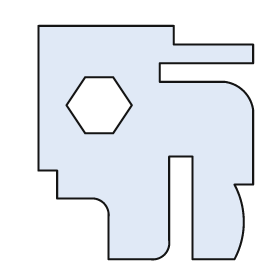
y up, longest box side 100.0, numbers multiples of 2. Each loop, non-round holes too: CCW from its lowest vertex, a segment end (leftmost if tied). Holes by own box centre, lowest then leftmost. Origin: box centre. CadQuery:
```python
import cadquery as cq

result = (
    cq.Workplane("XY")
    .moveTo(-16.0, -50.0)
    .lineTo(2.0, -50.0)
    .threePointArc((8.0, -48.0), (10.0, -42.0))
    .lineTo(10.0, -6.0)
    .lineTo(20.0, -6.0)
    .lineTo(20.0, -50.0)
    .lineTo(38.0, -50.0)
    .threePointArc((42.0, -34.0), (38.0, -18.0))
    .lineTo(46.0, -18.0)
    .lineTo(46.0, 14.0)
    .threePointArc((42.0, 22.0), (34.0, 26.0))
    .lineTo(6.0, 26.0)
    .lineTo(6.0, 34.0)
    .lineTo(46.0, 34.0)
    .lineTo(46.0, 42.0)
    .lineTo(12.0, 42.0)
    .lineTo(12.0, 50.0)
    .lineTo(-46.0, 50.0)
    .lineTo(-46.0, -12.0)
    .lineTo(-38.0, -12.0)
    .lineTo(-38.0, -24.0)
    .lineTo(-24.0, -24.0)
    .threePointArc((-18.0, -26.0), (-16.0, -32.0))
    .close()
    .moveTo(-26.0, 4.0)
    .lineTo(-14.0, 4.0)
    .lineTo(-6.0, 16.0)
    .lineTo(-14.0, 28.0)
    .lineTo(-26.0, 28.0)
    .lineTo(-34.0, 16.0)
    .close()
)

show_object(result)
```